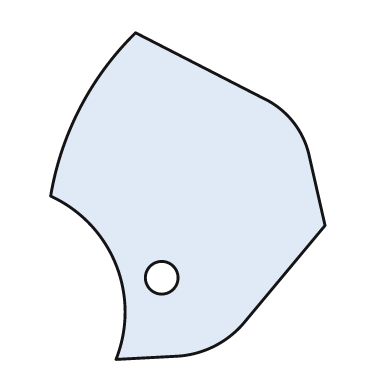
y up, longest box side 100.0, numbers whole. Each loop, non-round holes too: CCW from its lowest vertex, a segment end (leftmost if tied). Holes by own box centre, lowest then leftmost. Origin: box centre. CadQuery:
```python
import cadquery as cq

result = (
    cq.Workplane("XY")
    .moveTo(-22.0, -50.0)
    .lineTo(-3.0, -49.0)
    .threePointArc((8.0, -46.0), (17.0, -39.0))
    .lineTo(42.0, -9.0)
    .lineTo(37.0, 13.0)
    .threePointArc((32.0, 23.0), (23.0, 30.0))
    .lineTo(-16.0, 50.0)
    .threePointArc((-33.0, 27.0), (-42.0, 0.0))
    .threePointArc((-22.0, -21.0), (-22.0, -50.0))
    .close()
    .moveTo(-8.0, -25.0)
    .circle(5.0)
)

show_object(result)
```